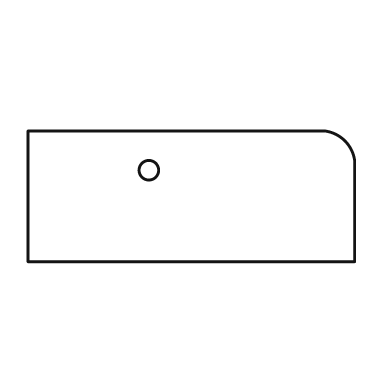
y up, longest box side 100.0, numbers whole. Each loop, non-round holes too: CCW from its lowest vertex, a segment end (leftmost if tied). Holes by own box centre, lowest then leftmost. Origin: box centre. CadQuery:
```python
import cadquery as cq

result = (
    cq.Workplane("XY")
    .moveTo(-50.0, -20.0)
    .lineTo(50.0, -20.0)
    .lineTo(50.0, 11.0)
    .threePointArc((47.0, 17.0), (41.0, 20.0))
    .lineTo(-50.0, 20.0)
    .close()
    .moveTo(-13.0, 8.0)
    .circle(3.0)
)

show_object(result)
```